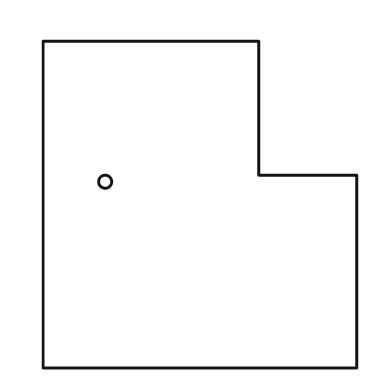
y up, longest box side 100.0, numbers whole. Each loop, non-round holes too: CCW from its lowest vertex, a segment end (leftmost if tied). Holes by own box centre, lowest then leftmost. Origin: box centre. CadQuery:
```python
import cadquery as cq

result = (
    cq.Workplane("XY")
    .moveTo(-48.0, -50.0)
    .lineTo(48.0, -50.0)
    .lineTo(48.0, 9.0)
    .lineTo(18.0, 9.0)
    .lineTo(18.0, 50.0)
    .lineTo(-48.0, 50.0)
    .close()
    .moveTo(-29.0, 7.0)
    .circle(2.0)
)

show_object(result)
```